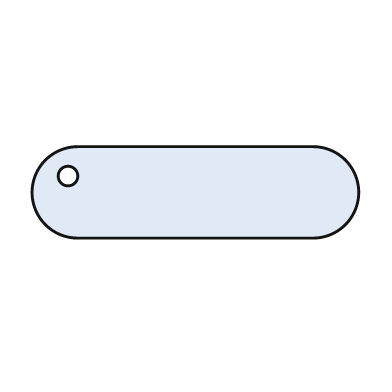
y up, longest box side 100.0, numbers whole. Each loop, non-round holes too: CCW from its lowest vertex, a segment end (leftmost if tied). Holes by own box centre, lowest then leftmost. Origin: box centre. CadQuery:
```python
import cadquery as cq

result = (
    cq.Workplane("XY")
    .moveTo(-36.0, -14.0)
    .lineTo(36.0, -14.0)
    .threePointArc((50.0, 0.0), (36.0, 14.0))
    .lineTo(-36.0, 14.0)
    .threePointArc((-50.0, 0.0), (-36.0, -14.0))
    .close()
    .moveTo(-39.0, 5.0)
    .circle(3.0)
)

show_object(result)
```